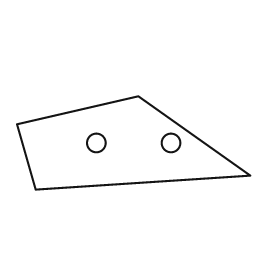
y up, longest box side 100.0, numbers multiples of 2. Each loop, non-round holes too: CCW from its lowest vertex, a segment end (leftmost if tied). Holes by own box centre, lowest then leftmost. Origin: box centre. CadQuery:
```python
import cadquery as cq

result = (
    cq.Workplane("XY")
    .moveTo(-42.0, -20.0)
    .lineTo(50.0, -14.0)
    .lineTo(2.0, 20.0)
    .lineTo(-50.0, 8.0)
    .close()
    .moveTo(-16.0, 0.0)
    .circle(4.0)
    .moveTo(16.0, 0.0)
    .circle(4.0)
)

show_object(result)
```